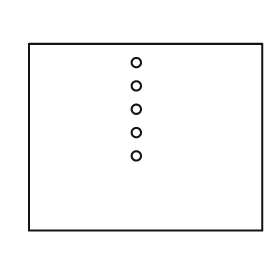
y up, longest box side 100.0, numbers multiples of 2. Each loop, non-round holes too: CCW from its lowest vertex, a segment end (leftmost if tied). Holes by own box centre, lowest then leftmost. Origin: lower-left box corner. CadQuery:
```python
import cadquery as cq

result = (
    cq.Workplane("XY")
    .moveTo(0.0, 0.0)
    .lineTo(100.0, 0.0)
    .lineTo(100.0, 80.0)
    .lineTo(0.0, 80.0)
    .close()
    .moveTo(46.0, 32.0)
    .circle(2.0)
    .moveTo(46.0, 42.0)
    .circle(2.0)
    .moveTo(46.0, 52.0)
    .circle(2.0)
    .moveTo(46.0, 62.0)
    .circle(2.0)
    .moveTo(46.0, 72.0)
    .circle(2.0)
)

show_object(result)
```